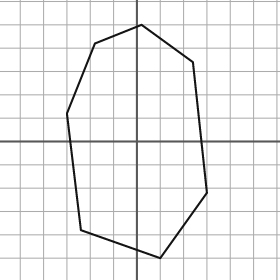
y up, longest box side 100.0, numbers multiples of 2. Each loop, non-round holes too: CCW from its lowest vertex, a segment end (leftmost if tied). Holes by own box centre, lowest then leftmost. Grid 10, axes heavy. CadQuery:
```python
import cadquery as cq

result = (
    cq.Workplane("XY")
    .moveTo(10.0, -50.0)
    .lineTo(30.0, -22.0)
    .lineTo(24.0, 34.0)
    .lineTo(2.0, 50.0)
    .lineTo(-18.0, 42.0)
    .lineTo(-30.0, 12.0)
    .lineTo(-24.0, -38.0)
    .close()
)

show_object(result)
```